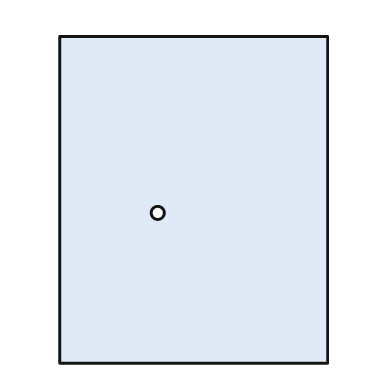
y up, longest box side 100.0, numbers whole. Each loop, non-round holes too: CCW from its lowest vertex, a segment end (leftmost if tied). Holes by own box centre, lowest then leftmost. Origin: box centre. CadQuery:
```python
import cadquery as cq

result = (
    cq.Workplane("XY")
    .moveTo(-41.0, -50.0)
    .lineTo(41.0, -50.0)
    .lineTo(41.0, 50.0)
    .lineTo(-41.0, 50.0)
    .close()
    .moveTo(-11.0, -4.0)
    .circle(2.0)
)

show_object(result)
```